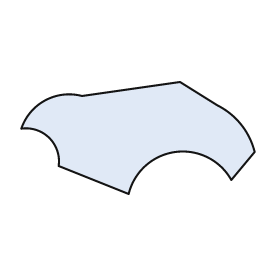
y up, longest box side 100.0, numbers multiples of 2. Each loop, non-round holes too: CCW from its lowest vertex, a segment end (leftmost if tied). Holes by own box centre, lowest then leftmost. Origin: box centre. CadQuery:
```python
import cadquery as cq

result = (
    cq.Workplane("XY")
    .moveTo(-4.0, -24.0)
    .threePointArc((16.0, -6.0), (40.0, -18.0))
    .lineTo(50.0, -6.0)
    .threePointArc((44.0, 6.0), (34.0, 14.0))
    .lineTo(18.0, 24.0)
    .lineTo(-24.0, 18.0)
    .threePointArc((-40.0, 16.0), (-50.0, 4.0))
    .threePointArc((-38.0, 0.0), (-34.0, -12.0))
    .close()
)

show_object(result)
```